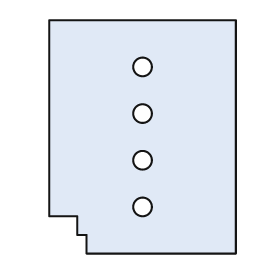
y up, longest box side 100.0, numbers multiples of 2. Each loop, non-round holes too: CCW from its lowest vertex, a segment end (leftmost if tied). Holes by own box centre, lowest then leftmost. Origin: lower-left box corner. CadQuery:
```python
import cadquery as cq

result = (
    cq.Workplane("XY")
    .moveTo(16.0, 0.0)
    .lineTo(80.0, 0.0)
    .lineTo(80.0, 100.0)
    .lineTo(0.0, 100.0)
    .lineTo(0.0, 16.0)
    .lineTo(12.0, 16.0)
    .lineTo(12.0, 8.0)
    .lineTo(16.0, 8.0)
    .close()
    .moveTo(40.0, 20.0)
    .circle(4.0)
    .moveTo(40.0, 40.0)
    .circle(4.0)
    .moveTo(40.0, 60.0)
    .circle(4.0)
    .moveTo(40.0, 80.0)
    .circle(4.0)
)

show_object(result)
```